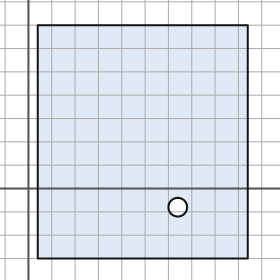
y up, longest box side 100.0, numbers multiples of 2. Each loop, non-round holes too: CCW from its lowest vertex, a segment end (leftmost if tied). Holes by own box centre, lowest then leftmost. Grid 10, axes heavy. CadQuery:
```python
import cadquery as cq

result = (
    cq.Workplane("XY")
    .moveTo(4.0, -30.0)
    .lineTo(94.0, -30.0)
    .lineTo(94.0, 70.0)
    .lineTo(4.0, 70.0)
    .close()
    .moveTo(64.0, -8.0)
    .circle(4.0)
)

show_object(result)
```